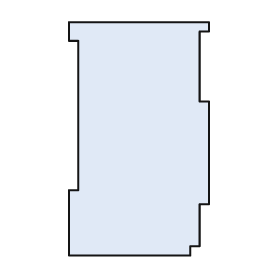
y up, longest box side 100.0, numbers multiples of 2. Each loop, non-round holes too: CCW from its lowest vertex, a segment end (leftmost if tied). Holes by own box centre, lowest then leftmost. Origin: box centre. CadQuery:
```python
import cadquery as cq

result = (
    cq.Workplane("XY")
    .moveTo(-30.0, -50.0)
    .lineTo(22.0, -50.0)
    .lineTo(22.0, -46.0)
    .lineTo(26.0, -46.0)
    .lineTo(26.0, -28.0)
    .lineTo(30.0, -28.0)
    .lineTo(30.0, 16.0)
    .lineTo(26.0, 16.0)
    .lineTo(26.0, 46.0)
    .lineTo(30.0, 46.0)
    .lineTo(30.0, 50.0)
    .lineTo(-30.0, 50.0)
    .lineTo(-30.0, 42.0)
    .lineTo(-26.0, 42.0)
    .lineTo(-26.0, -22.0)
    .lineTo(-30.0, -22.0)
    .close()
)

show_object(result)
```